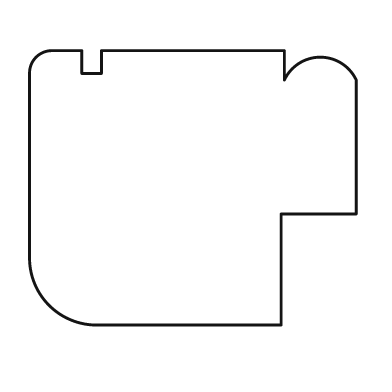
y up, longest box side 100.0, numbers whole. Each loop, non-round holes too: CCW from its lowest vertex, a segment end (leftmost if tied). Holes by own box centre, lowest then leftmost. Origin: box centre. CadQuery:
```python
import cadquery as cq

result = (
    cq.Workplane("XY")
    .moveTo(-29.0, -42.0)
    .lineTo(27.0, -42.0)
    .lineTo(27.0, -8.0)
    .lineTo(50.0, -8.0)
    .lineTo(50.0, 33.0)
    .threePointArc((39.0, 40.0), (28.0, 33.0))
    .lineTo(28.0, 42.0)
    .lineTo(-28.0, 42.0)
    .lineTo(-28.0, 35.0)
    .lineTo(-34.0, 35.0)
    .lineTo(-34.0, 42.0)
    .lineTo(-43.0, 42.0)
    .threePointArc((-48.0, 40.0), (-50.0, 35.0))
    .lineTo(-50.0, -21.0)
    .threePointArc((-44.0, -36.0), (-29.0, -42.0))
    .close()
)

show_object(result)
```